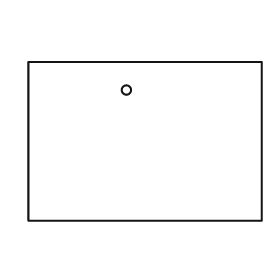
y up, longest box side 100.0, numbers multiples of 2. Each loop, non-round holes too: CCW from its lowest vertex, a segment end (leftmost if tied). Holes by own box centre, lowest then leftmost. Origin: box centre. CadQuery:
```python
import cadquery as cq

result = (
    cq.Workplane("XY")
    .moveTo(-50.0, -34.0)
    .lineTo(50.0, -34.0)
    .lineTo(50.0, 34.0)
    .lineTo(-50.0, 34.0)
    .close()
    .moveTo(-8.0, 22.0)
    .circle(2.0)
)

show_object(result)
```